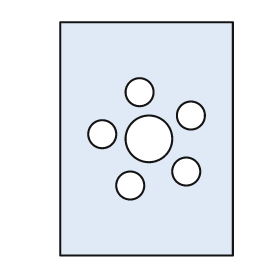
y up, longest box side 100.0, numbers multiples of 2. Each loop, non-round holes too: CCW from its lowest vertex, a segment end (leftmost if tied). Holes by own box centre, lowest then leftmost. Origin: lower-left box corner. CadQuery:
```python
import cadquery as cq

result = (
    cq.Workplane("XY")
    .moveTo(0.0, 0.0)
    .lineTo(74.0, 0.0)
    .lineTo(74.0, 100.0)
    .lineTo(0.0, 100.0)
    .close()
    .moveTo(30.0, 30.0)
    .circle(6.0)
    .moveTo(54.0, 36.0)
    .circle(6.0)
    .moveTo(38.0, 50.0)
    .circle(10.0)
    .moveTo(18.0, 52.0)
    .circle(6.0)
    .moveTo(56.0, 60.0)
    .circle(6.0)
    .moveTo(34.0, 70.0)
    .circle(6.0)
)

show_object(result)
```